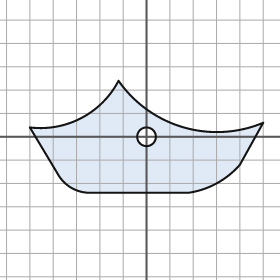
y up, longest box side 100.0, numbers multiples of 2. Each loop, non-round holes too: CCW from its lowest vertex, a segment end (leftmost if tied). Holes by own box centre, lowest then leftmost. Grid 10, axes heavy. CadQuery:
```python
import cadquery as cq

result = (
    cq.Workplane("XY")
    .moveTo(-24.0, -24.0)
    .lineTo(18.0, -24.0)
    .threePointArc((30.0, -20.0), (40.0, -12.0))
    .lineTo(50.0, 6.0)
    .threePointArc((16.0, 4.0), (-12.0, 24.0))
    .threePointArc((-28.0, 8.0), (-50.0, 4.0))
    .lineTo(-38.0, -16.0)
    .threePointArc((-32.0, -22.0), (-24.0, -24.0))
    .close()
    .moveTo(0.0, 0.0)
    .circle(4.0)
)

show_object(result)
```